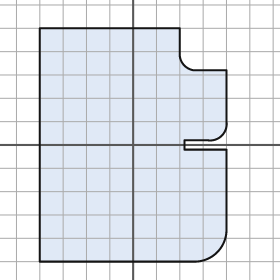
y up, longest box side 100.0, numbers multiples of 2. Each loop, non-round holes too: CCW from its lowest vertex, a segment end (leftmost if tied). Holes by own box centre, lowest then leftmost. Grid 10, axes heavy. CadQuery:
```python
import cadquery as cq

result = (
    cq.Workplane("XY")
    .moveTo(-40.0, -50.0)
    .lineTo(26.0, -50.0)
    .threePointArc((36.0, -46.0), (40.0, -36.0))
    .lineTo(40.0, -2.0)
    .lineTo(22.0, -2.0)
    .lineTo(22.0, 2.0)
    .lineTo(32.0, 2.0)
    .threePointArc((38.0, 4.0), (40.0, 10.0))
    .lineTo(40.0, 32.0)
    .lineTo(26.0, 32.0)
    .threePointArc((22.0, 34.0), (20.0, 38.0))
    .lineTo(20.0, 50.0)
    .lineTo(-40.0, 50.0)
    .close()
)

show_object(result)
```